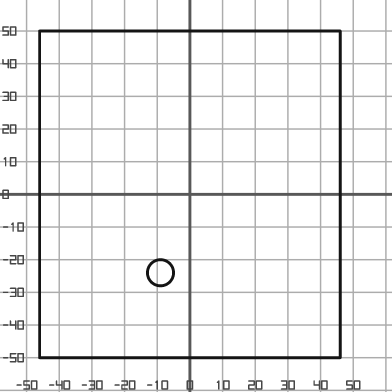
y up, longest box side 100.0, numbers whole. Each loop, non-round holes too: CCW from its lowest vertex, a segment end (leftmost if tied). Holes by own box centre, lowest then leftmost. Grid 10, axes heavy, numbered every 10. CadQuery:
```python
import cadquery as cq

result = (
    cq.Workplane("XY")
    .moveTo(-46.0, -50.0)
    .lineTo(46.0, -50.0)
    .lineTo(46.0, 50.0)
    .lineTo(-46.0, 50.0)
    .close()
    .moveTo(-9.0, -24.0)
    .circle(4.0)
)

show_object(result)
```